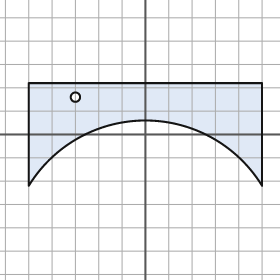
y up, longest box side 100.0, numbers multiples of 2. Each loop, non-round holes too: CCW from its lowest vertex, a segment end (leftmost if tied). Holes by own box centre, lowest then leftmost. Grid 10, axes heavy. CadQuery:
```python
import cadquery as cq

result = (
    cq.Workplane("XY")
    .moveTo(-50.0, -22.0)
    .threePointArc((0.0, 6.0), (50.0, -22.0))
    .lineTo(50.0, 22.0)
    .lineTo(-50.0, 22.0)
    .close()
    .moveTo(-30.0, 16.0)
    .circle(2.0)
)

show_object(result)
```